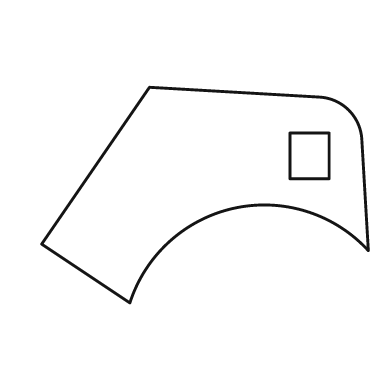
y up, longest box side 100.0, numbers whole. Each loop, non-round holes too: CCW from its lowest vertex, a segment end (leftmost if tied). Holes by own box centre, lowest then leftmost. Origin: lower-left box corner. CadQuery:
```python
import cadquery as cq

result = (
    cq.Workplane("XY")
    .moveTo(27.0, 0.0)
    .threePointArc((59.0, 29.0), (100.0, 16.0))
    .lineTo(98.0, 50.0)
    .threePointArc((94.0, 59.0), (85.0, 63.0))
    .lineTo(33.0, 66.0)
    .lineTo(0.0, 18.0)
    .close()
    .moveTo(76.0, 38.0)
    .lineTo(88.0, 38.0)
    .lineTo(88.0, 52.0)
    .lineTo(76.0, 52.0)
    .close()
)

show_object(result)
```